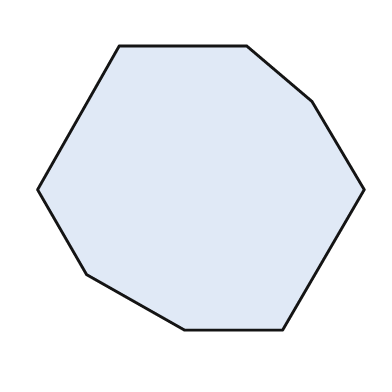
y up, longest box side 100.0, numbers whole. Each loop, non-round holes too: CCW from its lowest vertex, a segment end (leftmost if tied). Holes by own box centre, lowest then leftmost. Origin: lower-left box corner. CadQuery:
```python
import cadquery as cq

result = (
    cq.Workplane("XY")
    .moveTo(45.0, 0.0)
    .lineTo(75.0, 0.0)
    .lineTo(100.0, 43.0)
    .lineTo(84.0, 70.0)
    .lineTo(64.0, 87.0)
    .lineTo(25.0, 87.0)
    .lineTo(0.0, 43.0)
    .lineTo(15.0, 17.0)
    .close()
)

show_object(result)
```